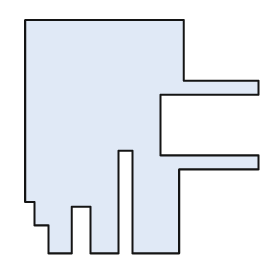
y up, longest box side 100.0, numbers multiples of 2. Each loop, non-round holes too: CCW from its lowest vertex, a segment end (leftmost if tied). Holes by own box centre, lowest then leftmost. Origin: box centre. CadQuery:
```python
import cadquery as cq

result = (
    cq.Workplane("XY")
    .moveTo(-40.0, -50.0)
    .lineTo(-30.0, -50.0)
    .lineTo(-30.0, -30.0)
    .lineTo(-22.0, -30.0)
    .lineTo(-22.0, -50.0)
    .lineTo(-10.0, -50.0)
    .lineTo(-10.0, -6.0)
    .lineTo(-4.0, -6.0)
    .lineTo(-4.0, -50.0)
    .lineTo(16.0, -50.0)
    .lineTo(16.0, -14.0)
    .lineTo(50.0, -14.0)
    .lineTo(50.0, -8.0)
    .lineTo(8.0, -8.0)
    .lineTo(8.0, 18.0)
    .lineTo(50.0, 18.0)
    .lineTo(50.0, 24.0)
    .lineTo(18.0, 24.0)
    .lineTo(18.0, 50.0)
    .lineTo(-50.0, 50.0)
    .lineTo(-50.0, -28.0)
    .lineTo(-46.0, -28.0)
    .lineTo(-46.0, -38.0)
    .lineTo(-40.0, -38.0)
    .close()
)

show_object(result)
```